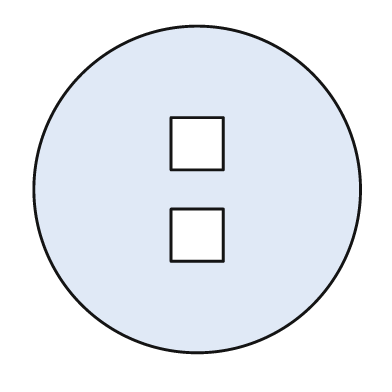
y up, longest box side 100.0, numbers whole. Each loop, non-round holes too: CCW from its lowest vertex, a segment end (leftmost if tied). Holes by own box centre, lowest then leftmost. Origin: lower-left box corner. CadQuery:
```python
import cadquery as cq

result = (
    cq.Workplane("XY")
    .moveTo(50.0, 50.0)
    .circle(50.0)
    .moveTo(42.0, 28.0)
    .lineTo(58.0, 28.0)
    .lineTo(58.0, 44.0)
    .lineTo(42.0, 44.0)
    .close()
    .moveTo(42.0, 56.0)
    .lineTo(58.0, 56.0)
    .lineTo(58.0, 72.0)
    .lineTo(42.0, 72.0)
    .close()
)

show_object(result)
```